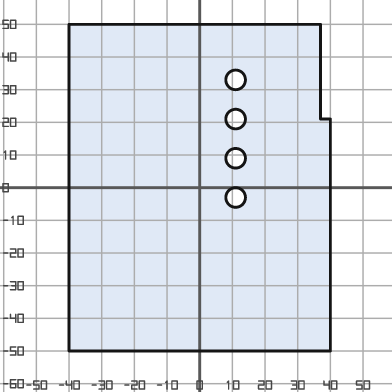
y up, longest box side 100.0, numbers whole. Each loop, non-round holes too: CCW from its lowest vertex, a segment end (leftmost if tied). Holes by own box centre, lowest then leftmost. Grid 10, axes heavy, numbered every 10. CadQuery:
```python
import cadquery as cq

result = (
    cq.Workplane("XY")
    .moveTo(-40.0, -50.0)
    .lineTo(40.0, -50.0)
    .lineTo(40.0, 21.0)
    .lineTo(37.0, 21.0)
    .lineTo(37.0, 50.0)
    .lineTo(-40.0, 50.0)
    .close()
    .moveTo(11.0, -3.0)
    .circle(3.0)
    .moveTo(11.0, 9.0)
    .circle(3.0)
    .moveTo(11.0, 21.0)
    .circle(3.0)
    .moveTo(11.0, 33.0)
    .circle(3.0)
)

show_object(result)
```